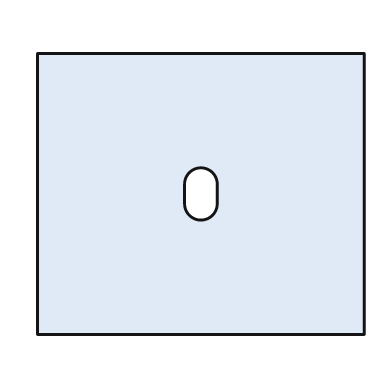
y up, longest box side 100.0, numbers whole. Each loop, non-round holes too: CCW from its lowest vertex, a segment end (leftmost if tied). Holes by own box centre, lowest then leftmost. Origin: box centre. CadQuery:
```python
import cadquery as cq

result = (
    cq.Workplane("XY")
    .moveTo(-50.0, -43.0)
    .lineTo(50.0, -43.0)
    .lineTo(50.0, 43.0)
    .lineTo(-50.0, 43.0)
    .close()
    .moveTo(-5.0, -3.0)
    .threePointArc((0.0, -8.0), (5.0, -3.0))
    .lineTo(5.0, 3.0)
    .threePointArc((0.0, 8.0), (-5.0, 3.0))
    .close()
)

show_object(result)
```